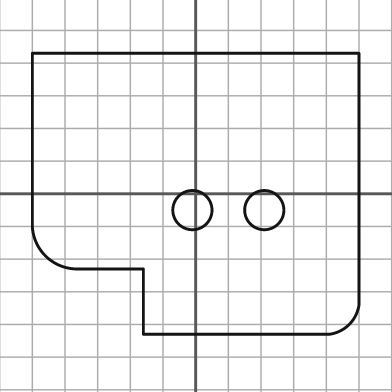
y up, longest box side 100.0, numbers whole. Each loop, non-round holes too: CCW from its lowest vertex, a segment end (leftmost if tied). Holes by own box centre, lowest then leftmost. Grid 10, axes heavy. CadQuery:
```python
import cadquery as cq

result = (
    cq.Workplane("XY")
    .moveTo(-16.0, -43.0)
    .lineTo(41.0, -43.0)
    .threePointArc((47.0, -40.0), (50.0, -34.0))
    .lineTo(50.0, 43.0)
    .lineTo(-50.0, 43.0)
    .lineTo(-50.0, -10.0)
    .threePointArc((-46.0, -19.0), (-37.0, -23.0))
    .lineTo(-16.0, -23.0)
    .close()
    .moveTo(-1.0, -5.0)
    .circle(6.0)
    .moveTo(21.0, -5.0)
    .circle(6.0)
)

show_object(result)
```